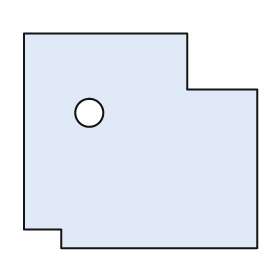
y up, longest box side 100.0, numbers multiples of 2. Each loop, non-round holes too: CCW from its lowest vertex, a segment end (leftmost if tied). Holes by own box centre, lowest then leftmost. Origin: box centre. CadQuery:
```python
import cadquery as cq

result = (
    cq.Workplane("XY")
    .moveTo(-34.0, -46.0)
    .lineTo(50.0, -46.0)
    .lineTo(50.0, 22.0)
    .lineTo(20.0, 22.0)
    .lineTo(20.0, 46.0)
    .lineTo(-50.0, 46.0)
    .lineTo(-50.0, -38.0)
    .lineTo(-34.0, -38.0)
    .close()
    .moveTo(-22.0, 12.0)
    .circle(6.0)
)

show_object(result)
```